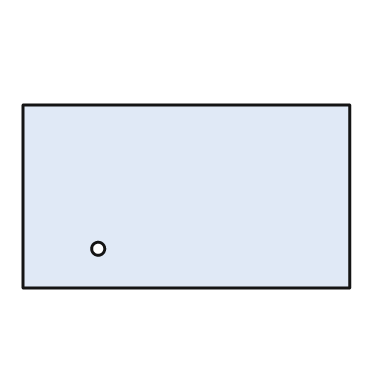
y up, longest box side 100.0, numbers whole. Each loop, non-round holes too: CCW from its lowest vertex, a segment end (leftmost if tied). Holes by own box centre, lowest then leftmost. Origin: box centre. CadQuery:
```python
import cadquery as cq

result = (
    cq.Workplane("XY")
    .moveTo(-50.0, -28.0)
    .lineTo(50.0, -28.0)
    .lineTo(50.0, 28.0)
    .lineTo(-50.0, 28.0)
    .close()
    .moveTo(-27.0, -16.0)
    .circle(2.0)
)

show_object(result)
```